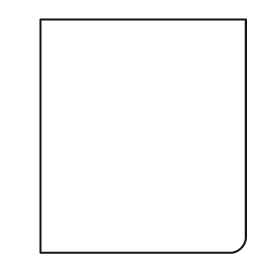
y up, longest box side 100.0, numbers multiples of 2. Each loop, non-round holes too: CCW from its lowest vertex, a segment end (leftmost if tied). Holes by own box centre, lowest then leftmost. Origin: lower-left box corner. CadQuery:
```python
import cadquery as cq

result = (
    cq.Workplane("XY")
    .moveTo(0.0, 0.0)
    .lineTo(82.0, 0.0)
    .threePointArc((86.0, 2.0), (88.0, 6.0))
    .lineTo(88.0, 100.0)
    .lineTo(0.0, 100.0)
    .close()
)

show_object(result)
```